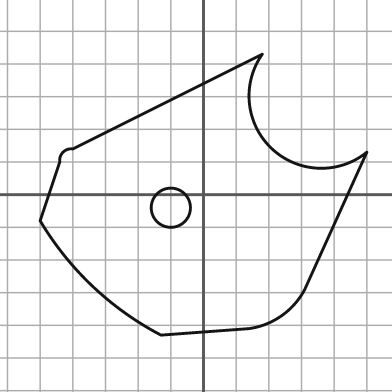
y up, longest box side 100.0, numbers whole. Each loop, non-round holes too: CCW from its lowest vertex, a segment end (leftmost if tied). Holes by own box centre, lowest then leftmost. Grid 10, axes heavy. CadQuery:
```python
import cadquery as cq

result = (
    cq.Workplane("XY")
    .moveTo(-13.0, -43.0)
    .lineTo(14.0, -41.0)
    .threePointArc((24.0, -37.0), (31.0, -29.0))
    .lineTo(50.0, 13.0)
    .threePointArc((21.0, 14.0), (18.0, 43.0))
    .lineTo(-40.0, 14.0)
    .threePointArc((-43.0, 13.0), (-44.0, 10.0))
    .lineTo(-50.0, -8.0)
    .threePointArc((-34.0, -28.0), (-13.0, -43.0))
    .close()
    .moveTo(-10.0, -4.0)
    .circle(6.0)
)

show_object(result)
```